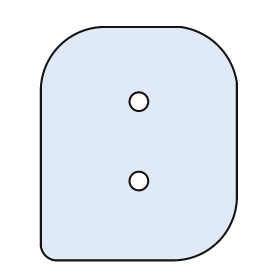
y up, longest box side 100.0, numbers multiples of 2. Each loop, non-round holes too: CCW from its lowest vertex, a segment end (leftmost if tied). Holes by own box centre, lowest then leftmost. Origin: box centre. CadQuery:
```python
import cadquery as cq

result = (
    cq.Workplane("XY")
    .moveTo(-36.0, -50.0)
    .lineTo(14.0, -50.0)
    .threePointArc((34.0, -42.0), (42.0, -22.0))
    .lineTo(42.0, 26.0)
    .threePointArc((34.0, 42.0), (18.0, 50.0))
    .lineTo(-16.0, 50.0)
    .threePointArc((-34.0, 42.0), (-42.0, 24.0))
    .lineTo(-42.0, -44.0)
    .threePointArc((-40.0, -48.0), (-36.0, -50.0))
    .close()
    .moveTo(0.0, -16.0)
    .circle(4.0)
    .moveTo(0.0, 18.0)
    .circle(4.0)
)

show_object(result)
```